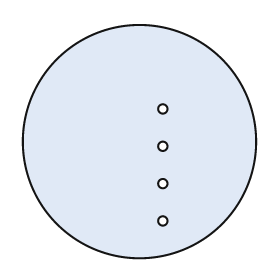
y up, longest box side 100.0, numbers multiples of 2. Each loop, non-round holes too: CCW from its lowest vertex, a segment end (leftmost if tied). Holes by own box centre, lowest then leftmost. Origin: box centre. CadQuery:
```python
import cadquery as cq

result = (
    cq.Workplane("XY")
    .moveTo(0.0, 0.0)
    .circle(50.0)
    .moveTo(10.0, -34.0)
    .circle(2.0)
    .moveTo(10.0, -18.0)
    .circle(2.0)
    .moveTo(10.0, -2.0)
    .circle(2.0)
    .moveTo(10.0, 14.0)
    .circle(2.0)
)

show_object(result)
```